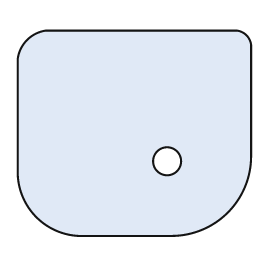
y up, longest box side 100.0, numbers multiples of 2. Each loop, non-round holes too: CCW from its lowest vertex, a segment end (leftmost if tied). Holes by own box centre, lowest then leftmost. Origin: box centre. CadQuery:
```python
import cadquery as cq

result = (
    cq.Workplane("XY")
    .moveTo(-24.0, -44.0)
    .lineTo(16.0, -44.0)
    .threePointArc((40.0, -34.0), (50.0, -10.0))
    .lineTo(50.0, 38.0)
    .threePointArc((48.0, 42.0), (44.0, 44.0))
    .lineTo(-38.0, 44.0)
    .threePointArc((-46.0, 40.0), (-50.0, 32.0))
    .lineTo(-50.0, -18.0)
    .threePointArc((-42.0, -36.0), (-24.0, -44.0))
    .close()
    .moveTo(14.0, -12.0)
    .circle(6.0)
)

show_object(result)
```